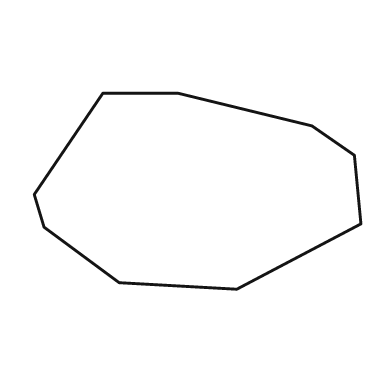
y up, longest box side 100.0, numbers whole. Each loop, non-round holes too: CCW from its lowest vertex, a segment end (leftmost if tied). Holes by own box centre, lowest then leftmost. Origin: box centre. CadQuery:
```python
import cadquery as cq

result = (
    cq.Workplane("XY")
    .moveTo(12.0, -30.0)
    .lineTo(50.0, -10.0)
    .lineTo(48.0, 11.0)
    .lineTo(35.0, 20.0)
    .lineTo(-6.0, 30.0)
    .lineTo(-29.0, 30.0)
    .lineTo(-50.0, -1.0)
    .lineTo(-47.0, -11.0)
    .lineTo(-24.0, -28.0)
    .close()
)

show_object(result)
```